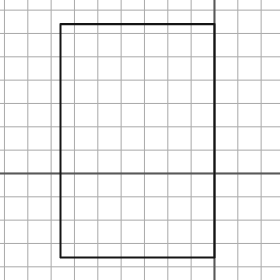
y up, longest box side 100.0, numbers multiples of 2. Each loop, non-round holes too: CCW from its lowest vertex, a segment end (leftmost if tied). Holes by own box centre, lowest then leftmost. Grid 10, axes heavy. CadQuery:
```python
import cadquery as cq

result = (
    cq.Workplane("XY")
    .moveTo(-66.0, -36.0)
    .lineTo(0.0, -36.0)
    .lineTo(0.0, 64.0)
    .lineTo(-66.0, 64.0)
    .close()
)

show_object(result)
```